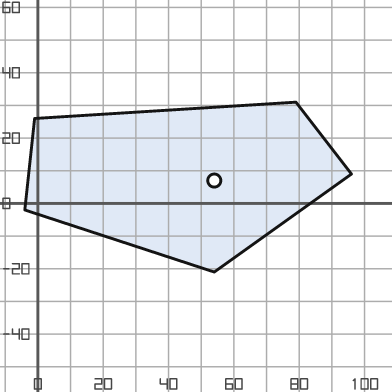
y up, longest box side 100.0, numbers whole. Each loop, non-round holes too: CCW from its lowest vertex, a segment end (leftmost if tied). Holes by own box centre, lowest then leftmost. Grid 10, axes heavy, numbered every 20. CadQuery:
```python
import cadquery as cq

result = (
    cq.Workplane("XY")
    .moveTo(54.0, -21.0)
    .lineTo(96.0, 9.0)
    .lineTo(79.0, 31.0)
    .lineTo(-1.0, 26.0)
    .lineTo(-4.0, -2.0)
    .close()
    .moveTo(54.0, 7.0)
    .circle(2.0)
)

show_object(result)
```